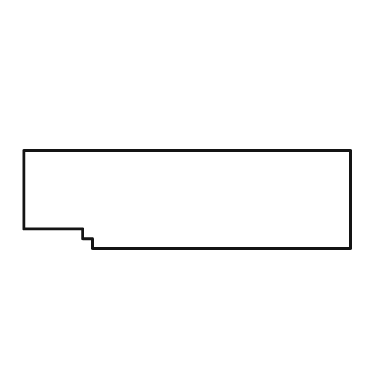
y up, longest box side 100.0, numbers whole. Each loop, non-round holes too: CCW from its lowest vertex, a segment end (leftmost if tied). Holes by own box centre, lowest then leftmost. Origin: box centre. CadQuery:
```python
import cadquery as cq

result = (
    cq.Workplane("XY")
    .moveTo(-29.0, -15.0)
    .lineTo(50.0, -15.0)
    .lineTo(50.0, 15.0)
    .lineTo(-50.0, 15.0)
    .lineTo(-50.0, -9.0)
    .lineTo(-32.0, -9.0)
    .lineTo(-32.0, -12.0)
    .lineTo(-29.0, -12.0)
    .close()
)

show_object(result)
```